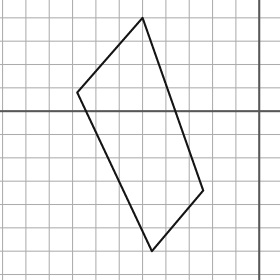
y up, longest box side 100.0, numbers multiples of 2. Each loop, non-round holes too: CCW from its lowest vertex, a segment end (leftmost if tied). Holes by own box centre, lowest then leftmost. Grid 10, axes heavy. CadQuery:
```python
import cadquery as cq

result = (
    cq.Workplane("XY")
    .moveTo(-46.0, -60.0)
    .lineTo(-24.0, -34.0)
    .lineTo(-50.0, 40.0)
    .lineTo(-78.0, 8.0)
    .close()
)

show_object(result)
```